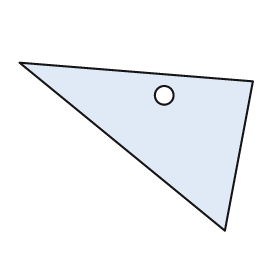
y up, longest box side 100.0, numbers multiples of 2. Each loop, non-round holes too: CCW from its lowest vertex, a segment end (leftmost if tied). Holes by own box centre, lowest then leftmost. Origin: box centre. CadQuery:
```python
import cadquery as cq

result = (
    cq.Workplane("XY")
    .moveTo(38.0, -36.0)
    .lineTo(50.0, 28.0)
    .lineTo(-50.0, 36.0)
    .close()
    .moveTo(12.0, 22.0)
    .circle(4.0)
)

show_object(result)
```